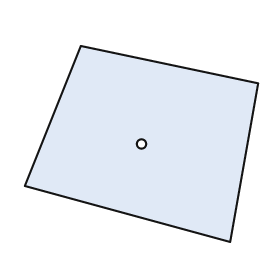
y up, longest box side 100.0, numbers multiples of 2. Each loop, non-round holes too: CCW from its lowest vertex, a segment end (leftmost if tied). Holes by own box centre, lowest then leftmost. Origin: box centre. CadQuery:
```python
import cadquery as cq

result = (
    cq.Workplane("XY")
    .moveTo(38.0, -42.0)
    .lineTo(50.0, 26.0)
    .lineTo(-26.0, 42.0)
    .lineTo(-50.0, -18.0)
    .close()
    .moveTo(0.0, 0.0)
    .circle(2.0)
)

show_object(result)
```